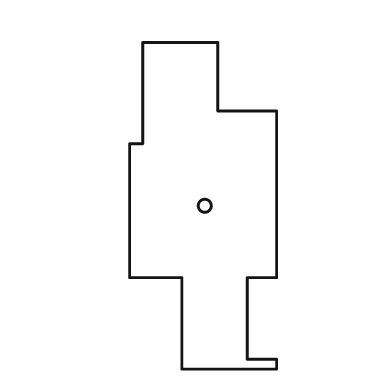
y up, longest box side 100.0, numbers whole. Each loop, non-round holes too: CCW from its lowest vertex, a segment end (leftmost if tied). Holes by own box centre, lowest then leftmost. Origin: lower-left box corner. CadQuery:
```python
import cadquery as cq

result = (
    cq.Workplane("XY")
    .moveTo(16.0, 0.0)
    .lineTo(45.0, 0.0)
    .lineTo(45.0, 3.0)
    .lineTo(36.0, 3.0)
    .lineTo(36.0, 28.0)
    .lineTo(45.0, 28.0)
    .lineTo(45.0, 79.0)
    .lineTo(27.0, 79.0)
    .lineTo(27.0, 100.0)
    .lineTo(4.0, 100.0)
    .lineTo(4.0, 69.0)
    .lineTo(0.0, 69.0)
    .lineTo(0.0, 28.0)
    .lineTo(16.0, 28.0)
    .close()
    .moveTo(23.0, 50.0)
    .circle(2.0)
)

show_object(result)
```